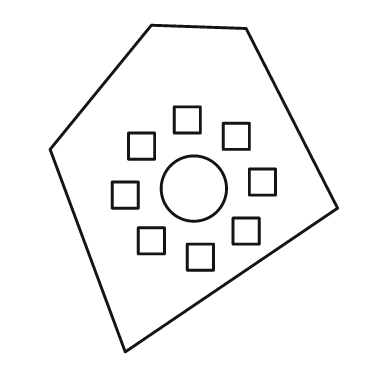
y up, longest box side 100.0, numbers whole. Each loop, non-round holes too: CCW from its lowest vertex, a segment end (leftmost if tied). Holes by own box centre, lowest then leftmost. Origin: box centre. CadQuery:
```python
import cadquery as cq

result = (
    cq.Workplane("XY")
    .moveTo(-21.0, -50.0)
    .lineTo(44.0, -6.0)
    .lineTo(16.0, 49.0)
    .lineTo(-13.0, 50.0)
    .lineTo(-44.0, 12.0)
    .close()
    .moveTo(-2.0, -25.0)
    .lineTo(6.0, -25.0)
    .lineTo(6.0, -17.0)
    .lineTo(-2.0, -17.0)
    .close()
    .moveTo(-17.0, -20.0)
    .lineTo(-9.0, -20.0)
    .lineTo(-9.0, -12.0)
    .lineTo(-17.0, -12.0)
    .close()
    .moveTo(12.0, -17.0)
    .lineTo(20.0, -17.0)
    .lineTo(20.0, -9.0)
    .lineTo(12.0, -9.0)
    .close()
    .moveTo(-25.0, -6.0)
    .lineTo(-17.0, -6.0)
    .lineTo(-17.0, 2.0)
    .lineTo(-25.0, 2.0)
    .close()
    .moveTo(0.0, 0.0)
    .circle(10.0)
    .moveTo(17.0, -2.0)
    .lineTo(25.0, -2.0)
    .lineTo(25.0, 6.0)
    .lineTo(17.0, 6.0)
    .close()
    .moveTo(-20.0, 9.0)
    .lineTo(-12.0, 9.0)
    .lineTo(-12.0, 17.0)
    .lineTo(-20.0, 17.0)
    .close()
    .moveTo(9.0, 12.0)
    .lineTo(17.0, 12.0)
    .lineTo(17.0, 20.0)
    .lineTo(9.0, 20.0)
    .close()
    .moveTo(-6.0, 17.0)
    .lineTo(2.0, 17.0)
    .lineTo(2.0, 25.0)
    .lineTo(-6.0, 25.0)
    .close()
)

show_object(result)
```